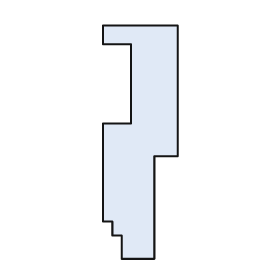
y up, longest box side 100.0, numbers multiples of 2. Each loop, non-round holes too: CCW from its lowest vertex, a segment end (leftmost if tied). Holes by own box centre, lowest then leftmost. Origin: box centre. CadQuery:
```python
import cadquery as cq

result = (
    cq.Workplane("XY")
    .moveTo(-8.0, -50.0)
    .lineTo(6.0, -50.0)
    .lineTo(6.0, -6.0)
    .lineTo(16.0, -6.0)
    .lineTo(16.0, 50.0)
    .lineTo(-16.0, 50.0)
    .lineTo(-16.0, 42.0)
    .lineTo(-4.0, 42.0)
    .lineTo(-4.0, 8.0)
    .lineTo(-16.0, 8.0)
    .lineTo(-16.0, -34.0)
    .lineTo(-12.0, -34.0)
    .lineTo(-12.0, -40.0)
    .lineTo(-8.0, -40.0)
    .close()
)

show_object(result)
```